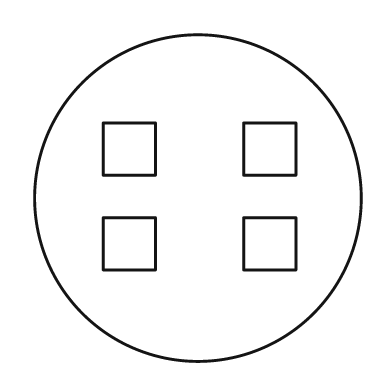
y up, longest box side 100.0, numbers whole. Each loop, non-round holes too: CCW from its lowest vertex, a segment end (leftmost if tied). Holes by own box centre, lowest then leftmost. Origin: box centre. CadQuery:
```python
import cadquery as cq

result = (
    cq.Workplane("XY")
    .moveTo(0.0, 0.0)
    .circle(50.0)
    .moveTo(-29.0, -22.0)
    .lineTo(-13.0, -22.0)
    .lineTo(-13.0, -6.0)
    .lineTo(-29.0, -6.0)
    .close()
    .moveTo(14.0, -22.0)
    .lineTo(30.0, -22.0)
    .lineTo(30.0, -6.0)
    .lineTo(14.0, -6.0)
    .close()
    .moveTo(-29.0, 7.0)
    .lineTo(-13.0, 7.0)
    .lineTo(-13.0, 23.0)
    .lineTo(-29.0, 23.0)
    .close()
    .moveTo(14.0, 7.0)
    .lineTo(30.0, 7.0)
    .lineTo(30.0, 23.0)
    .lineTo(14.0, 23.0)
    .close()
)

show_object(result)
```